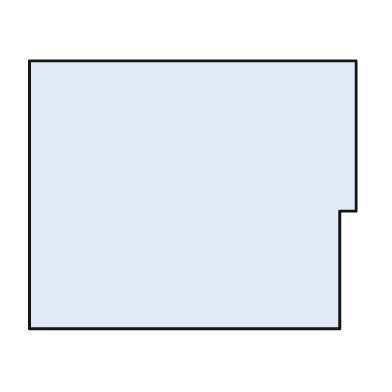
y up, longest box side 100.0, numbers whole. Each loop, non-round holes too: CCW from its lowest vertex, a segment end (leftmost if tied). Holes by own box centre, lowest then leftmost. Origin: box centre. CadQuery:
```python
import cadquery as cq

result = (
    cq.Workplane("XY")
    .moveTo(-50.0, -41.0)
    .lineTo(45.0, -41.0)
    .lineTo(45.0, -5.0)
    .lineTo(50.0, -5.0)
    .lineTo(50.0, 41.0)
    .lineTo(-50.0, 41.0)
    .close()
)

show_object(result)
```